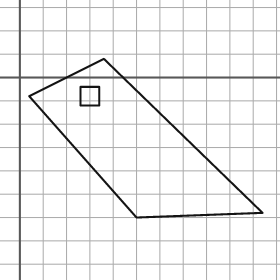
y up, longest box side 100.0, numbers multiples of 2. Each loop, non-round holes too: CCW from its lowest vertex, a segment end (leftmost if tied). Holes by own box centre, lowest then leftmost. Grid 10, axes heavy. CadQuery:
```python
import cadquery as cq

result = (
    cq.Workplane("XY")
    .moveTo(50.0, -60.0)
    .lineTo(104.0, -58.0)
    .lineTo(36.0, 8.0)
    .lineTo(4.0, -8.0)
    .close()
    .moveTo(26.0, -12.0)
    .lineTo(34.0, -12.0)
    .lineTo(34.0, -4.0)
    .lineTo(26.0, -4.0)
    .close()
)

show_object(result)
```